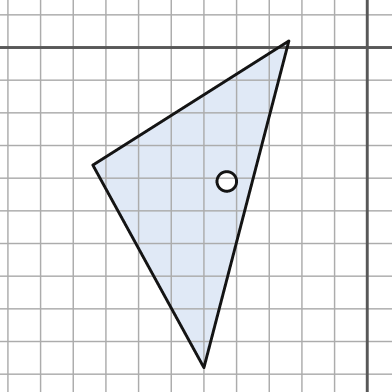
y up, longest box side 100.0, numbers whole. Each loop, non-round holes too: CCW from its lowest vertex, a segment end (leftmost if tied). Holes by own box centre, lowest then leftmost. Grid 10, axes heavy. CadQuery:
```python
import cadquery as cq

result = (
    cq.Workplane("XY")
    .moveTo(-50.0, -98.0)
    .lineTo(-24.0, 2.0)
    .lineTo(-84.0, -36.0)
    .close()
    .moveTo(-43.0, -41.0)
    .circle(3.0)
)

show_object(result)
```